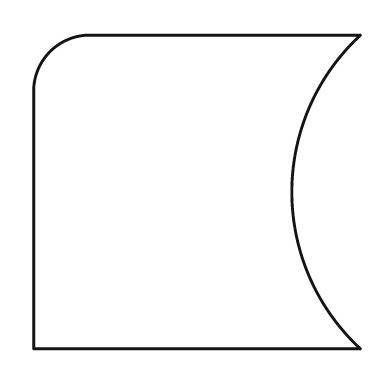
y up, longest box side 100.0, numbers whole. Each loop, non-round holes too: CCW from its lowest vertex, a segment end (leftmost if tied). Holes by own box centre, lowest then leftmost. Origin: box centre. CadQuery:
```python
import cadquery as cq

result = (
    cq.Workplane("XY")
    .moveTo(-50.0, -48.0)
    .lineTo(50.0, -48.0)
    .threePointArc((29.0, 0.0), (50.0, 48.0))
    .lineTo(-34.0, 48.0)
    .threePointArc((-45.0, 43.0), (-50.0, 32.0))
    .close()
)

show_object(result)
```